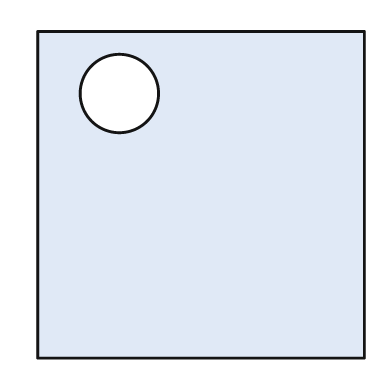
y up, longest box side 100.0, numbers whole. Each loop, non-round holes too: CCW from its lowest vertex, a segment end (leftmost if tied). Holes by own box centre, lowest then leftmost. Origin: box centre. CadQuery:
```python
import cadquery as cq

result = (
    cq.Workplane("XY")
    .moveTo(-50.0, -50.0)
    .lineTo(50.0, -50.0)
    .lineTo(50.0, 50.0)
    .lineTo(-50.0, 50.0)
    .close()
    .moveTo(-25.0, 31.0)
    .circle(12.0)
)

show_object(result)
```